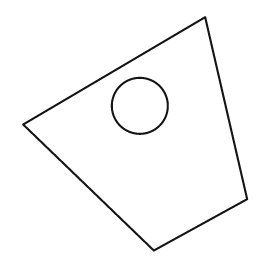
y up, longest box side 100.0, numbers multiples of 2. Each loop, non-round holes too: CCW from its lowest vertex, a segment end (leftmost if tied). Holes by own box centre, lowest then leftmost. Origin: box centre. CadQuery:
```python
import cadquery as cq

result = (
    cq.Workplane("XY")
    .moveTo(8.0, -50.0)
    .lineTo(48.0, -28.0)
    .lineTo(30.0, 50.0)
    .lineTo(-48.0, 4.0)
    .close()
    .moveTo(2.0, 12.0)
    .circle(12.0)
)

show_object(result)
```